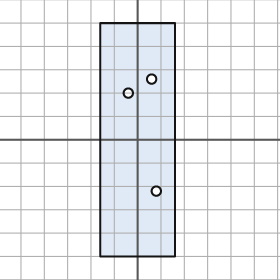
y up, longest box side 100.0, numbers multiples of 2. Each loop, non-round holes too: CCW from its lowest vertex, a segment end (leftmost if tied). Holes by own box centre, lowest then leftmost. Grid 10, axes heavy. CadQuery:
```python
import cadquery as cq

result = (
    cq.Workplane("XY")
    .moveTo(-16.0, -50.0)
    .lineTo(16.0, -50.0)
    .lineTo(16.0, 50.0)
    .lineTo(-16.0, 50.0)
    .close()
    .moveTo(8.0, -22.0)
    .circle(2.0)
    .moveTo(-4.0, 20.0)
    .circle(2.0)
    .moveTo(6.0, 26.0)
    .circle(2.0)
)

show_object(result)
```